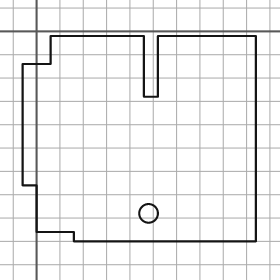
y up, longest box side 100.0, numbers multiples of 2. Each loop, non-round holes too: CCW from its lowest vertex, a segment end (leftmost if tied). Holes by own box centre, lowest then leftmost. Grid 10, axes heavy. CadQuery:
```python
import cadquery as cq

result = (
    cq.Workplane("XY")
    .moveTo(16.0, -90.0)
    .lineTo(94.0, -90.0)
    .lineTo(94.0, -2.0)
    .lineTo(52.0, -2.0)
    .lineTo(52.0, -28.0)
    .lineTo(46.0, -28.0)
    .lineTo(46.0, -2.0)
    .lineTo(6.0, -2.0)
    .lineTo(6.0, -14.0)
    .lineTo(-6.0, -14.0)
    .lineTo(-6.0, -66.0)
    .lineTo(0.0, -66.0)
    .lineTo(0.0, -86.0)
    .lineTo(16.0, -86.0)
    .close()
    .moveTo(48.0, -78.0)
    .circle(4.0)
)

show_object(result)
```